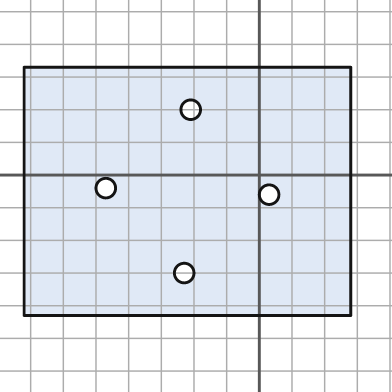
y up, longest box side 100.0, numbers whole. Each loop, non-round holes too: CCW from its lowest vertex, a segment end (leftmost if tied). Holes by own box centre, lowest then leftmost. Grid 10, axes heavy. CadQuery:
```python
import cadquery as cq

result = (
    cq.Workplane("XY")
    .moveTo(-72.0, -43.0)
    .lineTo(28.0, -43.0)
    .lineTo(28.0, 33.0)
    .lineTo(-72.0, 33.0)
    .close()
    .moveTo(-23.0, -30.0)
    .circle(3.0)
    .moveTo(3.0, -6.0)
    .circle(3.0)
    .moveTo(-47.0, -4.0)
    .circle(3.0)
    .moveTo(-21.0, 20.0)
    .circle(3.0)
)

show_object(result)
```